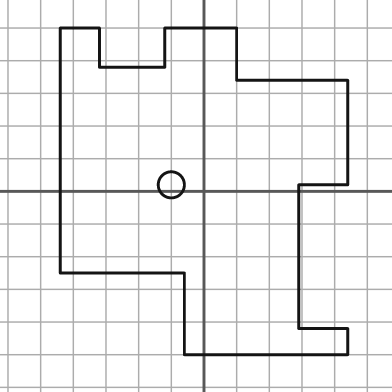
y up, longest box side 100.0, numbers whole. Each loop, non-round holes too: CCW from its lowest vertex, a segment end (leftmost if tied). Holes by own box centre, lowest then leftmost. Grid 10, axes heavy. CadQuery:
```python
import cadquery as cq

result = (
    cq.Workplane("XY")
    .moveTo(-6.0, -50.0)
    .lineTo(44.0, -50.0)
    .lineTo(44.0, -42.0)
    .lineTo(29.0, -42.0)
    .lineTo(29.0, 2.0)
    .lineTo(44.0, 2.0)
    .lineTo(44.0, 34.0)
    .lineTo(10.0, 34.0)
    .lineTo(10.0, 50.0)
    .lineTo(-12.0, 50.0)
    .lineTo(-12.0, 38.0)
    .lineTo(-32.0, 38.0)
    .lineTo(-32.0, 50.0)
    .lineTo(-44.0, 50.0)
    .lineTo(-44.0, -25.0)
    .lineTo(-6.0, -25.0)
    .close()
    .moveTo(-10.0, 2.0)
    .circle(4.0)
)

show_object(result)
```